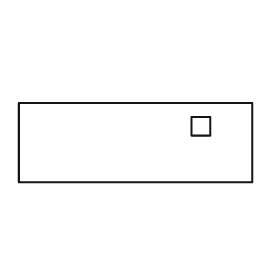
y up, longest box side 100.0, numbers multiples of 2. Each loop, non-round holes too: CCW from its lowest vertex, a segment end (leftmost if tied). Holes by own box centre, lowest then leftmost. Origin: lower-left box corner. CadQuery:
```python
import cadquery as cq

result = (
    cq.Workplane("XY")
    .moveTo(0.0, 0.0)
    .lineTo(100.0, 0.0)
    .lineTo(100.0, 34.0)
    .lineTo(0.0, 34.0)
    .close()
    .moveTo(74.0, 20.0)
    .lineTo(82.0, 20.0)
    .lineTo(82.0, 28.0)
    .lineTo(74.0, 28.0)
    .close()
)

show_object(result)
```